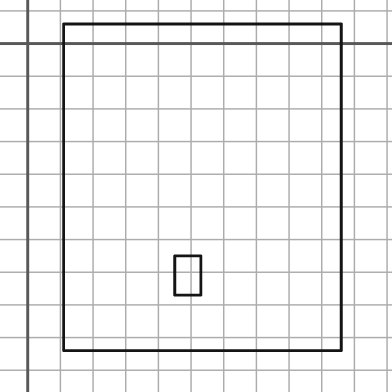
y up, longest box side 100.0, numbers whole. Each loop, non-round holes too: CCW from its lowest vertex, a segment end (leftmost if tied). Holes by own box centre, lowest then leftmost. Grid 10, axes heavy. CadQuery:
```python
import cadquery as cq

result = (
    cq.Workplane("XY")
    .moveTo(11.0, -94.0)
    .lineTo(96.0, -94.0)
    .lineTo(96.0, 6.0)
    .lineTo(11.0, 6.0)
    .close()
    .moveTo(45.0, -77.0)
    .lineTo(53.0, -77.0)
    .lineTo(53.0, -65.0)
    .lineTo(45.0, -65.0)
    .close()
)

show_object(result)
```